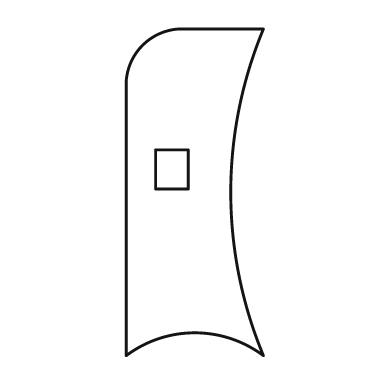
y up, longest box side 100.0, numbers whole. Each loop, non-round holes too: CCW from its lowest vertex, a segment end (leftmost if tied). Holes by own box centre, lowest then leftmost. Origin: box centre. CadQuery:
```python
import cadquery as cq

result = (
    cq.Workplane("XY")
    .moveTo(-21.0, -50.0)
    .threePointArc((0.0, -43.0), (21.0, -50.0))
    .threePointArc((11.0, 0.0), (21.0, 50.0))
    .lineTo(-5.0, 50.0)
    .threePointArc((-16.0, 45.0), (-21.0, 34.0))
    .close()
    .moveTo(-12.0, 1.0)
    .lineTo(-2.0, 1.0)
    .lineTo(-2.0, 13.0)
    .lineTo(-12.0, 13.0)
    .close()
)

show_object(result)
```